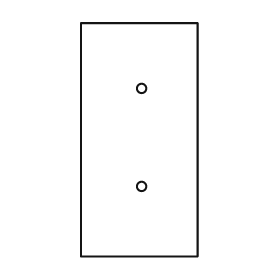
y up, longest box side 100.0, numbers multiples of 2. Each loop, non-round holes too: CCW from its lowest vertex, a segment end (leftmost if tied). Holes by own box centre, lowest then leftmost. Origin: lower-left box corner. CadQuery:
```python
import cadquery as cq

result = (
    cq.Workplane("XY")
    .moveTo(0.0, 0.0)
    .lineTo(50.0, 0.0)
    .lineTo(50.0, 100.0)
    .lineTo(0.0, 100.0)
    .close()
    .moveTo(26.0, 30.0)
    .circle(2.0)
    .moveTo(26.0, 72.0)
    .circle(2.0)
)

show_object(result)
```